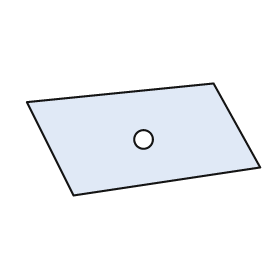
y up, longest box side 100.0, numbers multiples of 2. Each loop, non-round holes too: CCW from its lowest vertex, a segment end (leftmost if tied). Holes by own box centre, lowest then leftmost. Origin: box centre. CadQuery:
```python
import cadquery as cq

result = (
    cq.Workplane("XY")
    .moveTo(-30.0, -24.0)
    .lineTo(50.0, -12.0)
    .lineTo(30.0, 24.0)
    .lineTo(-50.0, 16.0)
    .close()
    .moveTo(0.0, 0.0)
    .circle(4.0)
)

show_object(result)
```